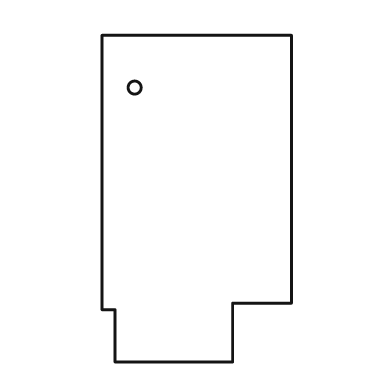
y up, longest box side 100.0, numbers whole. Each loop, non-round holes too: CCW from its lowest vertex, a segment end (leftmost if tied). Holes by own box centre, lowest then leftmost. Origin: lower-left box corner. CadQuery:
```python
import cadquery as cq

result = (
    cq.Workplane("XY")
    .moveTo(4.0, 0.0)
    .lineTo(40.0, 0.0)
    .lineTo(40.0, 18.0)
    .lineTo(58.0, 18.0)
    .lineTo(58.0, 100.0)
    .lineTo(0.0, 100.0)
    .lineTo(0.0, 16.0)
    .lineTo(4.0, 16.0)
    .close()
    .moveTo(10.0, 84.0)
    .circle(2.0)
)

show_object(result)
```